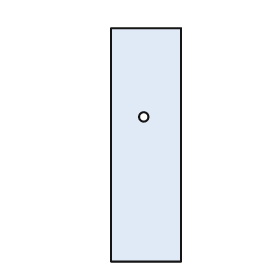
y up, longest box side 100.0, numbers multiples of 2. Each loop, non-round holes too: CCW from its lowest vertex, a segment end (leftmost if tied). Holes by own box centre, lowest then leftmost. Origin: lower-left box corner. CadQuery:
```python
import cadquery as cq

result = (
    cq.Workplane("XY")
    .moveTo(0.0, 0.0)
    .lineTo(30.0, 0.0)
    .lineTo(30.0, 100.0)
    .lineTo(0.0, 100.0)
    .close()
    .moveTo(14.0, 62.0)
    .circle(2.0)
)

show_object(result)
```